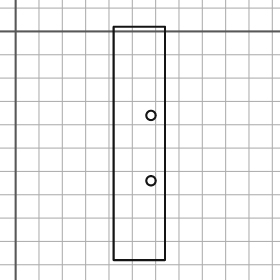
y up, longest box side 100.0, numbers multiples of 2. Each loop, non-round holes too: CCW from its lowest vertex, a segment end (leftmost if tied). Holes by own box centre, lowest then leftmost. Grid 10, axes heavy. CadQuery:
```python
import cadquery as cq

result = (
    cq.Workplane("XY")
    .moveTo(42.0, -98.0)
    .lineTo(64.0, -98.0)
    .lineTo(64.0, 2.0)
    .lineTo(42.0, 2.0)
    .close()
    .moveTo(58.0, -64.0)
    .circle(2.0)
    .moveTo(58.0, -36.0)
    .circle(2.0)
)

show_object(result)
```